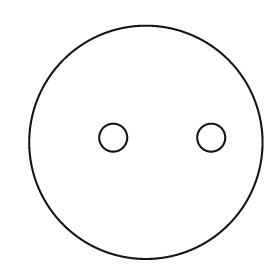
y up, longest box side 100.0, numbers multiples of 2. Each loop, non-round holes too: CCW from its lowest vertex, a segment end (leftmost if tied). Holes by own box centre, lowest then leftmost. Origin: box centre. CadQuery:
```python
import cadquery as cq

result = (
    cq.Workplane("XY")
    .moveTo(0.0, 0.0)
    .circle(50.0)
    .moveTo(-14.0, 2.0)
    .circle(6.0)
    .moveTo(28.0, 2.0)
    .circle(6.0)
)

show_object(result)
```